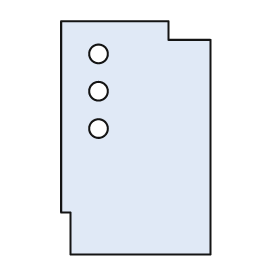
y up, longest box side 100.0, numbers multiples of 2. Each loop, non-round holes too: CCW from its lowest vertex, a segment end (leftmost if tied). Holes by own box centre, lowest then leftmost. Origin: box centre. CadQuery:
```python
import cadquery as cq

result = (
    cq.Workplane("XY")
    .moveTo(-28.0, -50.0)
    .lineTo(32.0, -50.0)
    .lineTo(32.0, 42.0)
    .lineTo(14.0, 42.0)
    .lineTo(14.0, 50.0)
    .lineTo(-32.0, 50.0)
    .lineTo(-32.0, -32.0)
    .lineTo(-28.0, -32.0)
    .close()
    .moveTo(-16.0, 4.0)
    .circle(4.0)
    .moveTo(-16.0, 20.0)
    .circle(4.0)
    .moveTo(-16.0, 36.0)
    .circle(4.0)
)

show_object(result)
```